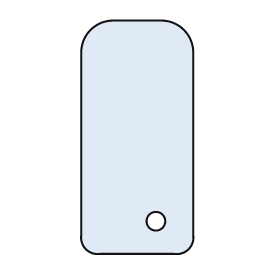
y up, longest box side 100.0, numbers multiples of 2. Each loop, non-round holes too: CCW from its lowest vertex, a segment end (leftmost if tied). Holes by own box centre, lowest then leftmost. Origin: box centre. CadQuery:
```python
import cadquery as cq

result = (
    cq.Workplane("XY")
    .moveTo(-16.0, -50.0)
    .lineTo(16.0, -50.0)
    .threePointArc((22.0, -48.0), (24.0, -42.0))
    .lineTo(24.0, 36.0)
    .threePointArc((20.0, 46.0), (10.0, 50.0))
    .lineTo(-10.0, 50.0)
    .threePointArc((-20.0, 46.0), (-24.0, 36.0))
    .lineTo(-24.0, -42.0)
    .threePointArc((-22.0, -48.0), (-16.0, -50.0))
    .close()
    .moveTo(8.0, -36.0)
    .circle(4.0)
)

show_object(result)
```